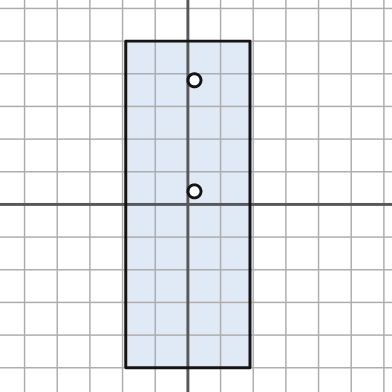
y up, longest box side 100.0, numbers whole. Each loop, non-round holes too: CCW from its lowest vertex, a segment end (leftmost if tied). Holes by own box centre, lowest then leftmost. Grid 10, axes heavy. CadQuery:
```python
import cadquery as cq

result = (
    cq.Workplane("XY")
    .moveTo(-19.0, -50.0)
    .lineTo(19.0, -50.0)
    .lineTo(19.0, 50.0)
    .lineTo(-19.0, 50.0)
    .close()
    .moveTo(2.0, 4.0)
    .circle(2.0)
    .moveTo(2.0, 38.0)
    .circle(2.0)
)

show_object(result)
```